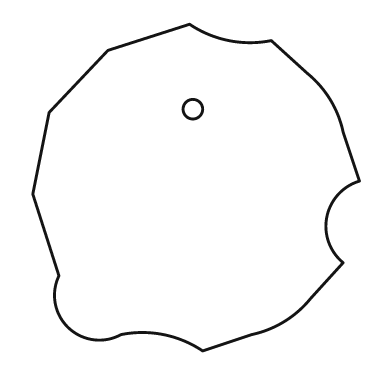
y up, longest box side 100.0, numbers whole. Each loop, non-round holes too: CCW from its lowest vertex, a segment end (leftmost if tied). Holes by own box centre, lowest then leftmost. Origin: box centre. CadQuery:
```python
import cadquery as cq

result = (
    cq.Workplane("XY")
    .moveTo(2.0, -50.0)
    .lineTo(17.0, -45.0)
    .threePointArc((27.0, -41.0), (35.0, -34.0))
    .lineTo(45.0, -23.0)
    .threePointArc((40.0, -9.0), (50.0, 2.0))
    .lineTo(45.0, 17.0)
    .threePointArc((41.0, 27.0), (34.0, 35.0))
    .lineTo(23.0, 45.0)
    .threePointArc((10.0, 45.0), (-2.0, 50.0))
    .lineTo(-27.0, 42.0)
    .lineTo(-45.0, 23.0)
    .lineTo(-50.0, -2.0)
    .lineTo(-42.0, -27.0)
    .threePointArc((-39.0, -43.0), (-23.0, -45.0))
    .threePointArc((-10.0, -45.0), (2.0, -50.0))
    .close()
    .moveTo(-1.0, 24.0)
    .circle(3.0)
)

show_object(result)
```